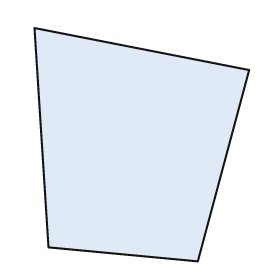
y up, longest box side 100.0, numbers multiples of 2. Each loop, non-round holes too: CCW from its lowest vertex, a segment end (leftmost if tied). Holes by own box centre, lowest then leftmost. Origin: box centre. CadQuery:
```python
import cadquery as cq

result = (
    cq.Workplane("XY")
    .moveTo(24.0, -50.0)
    .lineTo(46.0, 32.0)
    .lineTo(-46.0, 50.0)
    .lineTo(-40.0, -44.0)
    .close()
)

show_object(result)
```